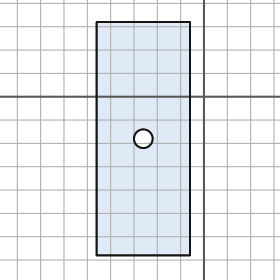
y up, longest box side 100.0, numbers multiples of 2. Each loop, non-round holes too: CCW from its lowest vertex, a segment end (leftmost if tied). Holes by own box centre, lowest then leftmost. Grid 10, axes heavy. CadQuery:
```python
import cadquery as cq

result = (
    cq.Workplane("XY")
    .moveTo(-46.0, -68.0)
    .lineTo(-6.0, -68.0)
    .lineTo(-6.0, 32.0)
    .lineTo(-46.0, 32.0)
    .close()
    .moveTo(-26.0, -18.0)
    .circle(4.0)
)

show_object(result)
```